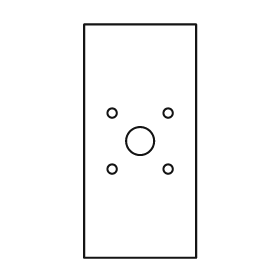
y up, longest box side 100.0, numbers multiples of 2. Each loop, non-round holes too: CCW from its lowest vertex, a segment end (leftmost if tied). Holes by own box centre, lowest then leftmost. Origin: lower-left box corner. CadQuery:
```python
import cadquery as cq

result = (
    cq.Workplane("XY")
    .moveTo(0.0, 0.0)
    .lineTo(48.0, 0.0)
    .lineTo(48.0, 100.0)
    .lineTo(0.0, 100.0)
    .close()
    .moveTo(12.0, 38.0)
    .circle(2.0)
    .moveTo(36.0, 38.0)
    .circle(2.0)
    .moveTo(24.0, 50.0)
    .circle(6.0)
    .moveTo(12.0, 62.0)
    .circle(2.0)
    .moveTo(36.0, 62.0)
    .circle(2.0)
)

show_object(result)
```